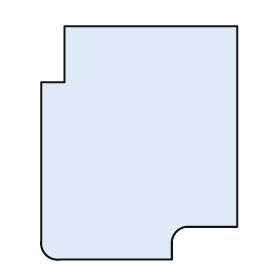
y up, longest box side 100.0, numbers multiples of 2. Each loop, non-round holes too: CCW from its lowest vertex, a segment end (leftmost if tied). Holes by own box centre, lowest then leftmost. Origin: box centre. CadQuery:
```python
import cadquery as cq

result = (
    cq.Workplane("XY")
    .moveTo(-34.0, -50.0)
    .lineTo(14.0, -50.0)
    .lineTo(14.0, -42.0)
    .threePointArc((16.0, -38.0), (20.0, -36.0))
    .lineTo(42.0, -36.0)
    .lineTo(42.0, 50.0)
    .lineTo(-32.0, 50.0)
    .lineTo(-32.0, 26.0)
    .lineTo(-42.0, 26.0)
    .lineTo(-42.0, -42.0)
    .threePointArc((-40.0, -48.0), (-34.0, -50.0))
    .close()
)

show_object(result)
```